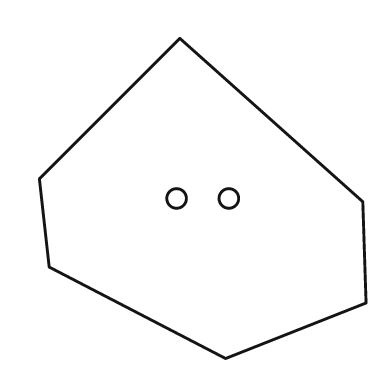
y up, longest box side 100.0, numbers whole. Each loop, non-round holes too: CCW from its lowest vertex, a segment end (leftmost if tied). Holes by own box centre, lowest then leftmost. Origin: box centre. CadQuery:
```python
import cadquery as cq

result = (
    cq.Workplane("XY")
    .moveTo(7.0, -49.0)
    .lineTo(50.0, -32.0)
    .lineTo(49.0, -1.0)
    .lineTo(-7.0, 49.0)
    .lineTo(-50.0, 6.0)
    .lineTo(-47.0, -21.0)
    .close()
    .moveTo(-8.0, 0.0)
    .circle(3.0)
    .moveTo(8.0, 0.0)
    .circle(3.0)
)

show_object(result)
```